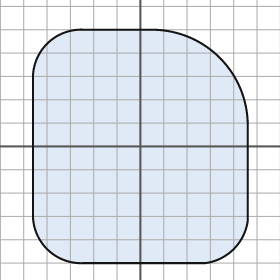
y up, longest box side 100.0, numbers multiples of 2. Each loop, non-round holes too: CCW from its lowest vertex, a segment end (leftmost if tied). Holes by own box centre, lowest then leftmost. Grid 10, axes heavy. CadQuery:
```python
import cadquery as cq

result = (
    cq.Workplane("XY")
    .moveTo(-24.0, -50.0)
    .lineTo(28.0, -50.0)
    .threePointArc((40.0, -44.0), (46.0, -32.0))
    .lineTo(46.0, 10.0)
    .threePointArc((34.0, 38.0), (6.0, 50.0))
    .lineTo(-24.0, 50.0)
    .threePointArc((-40.0, 44.0), (-46.0, 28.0))
    .lineTo(-46.0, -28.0)
    .threePointArc((-40.0, -44.0), (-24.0, -50.0))
    .close()
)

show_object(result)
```